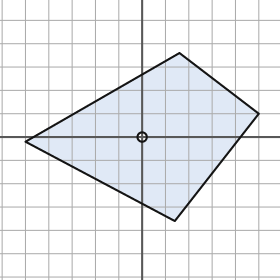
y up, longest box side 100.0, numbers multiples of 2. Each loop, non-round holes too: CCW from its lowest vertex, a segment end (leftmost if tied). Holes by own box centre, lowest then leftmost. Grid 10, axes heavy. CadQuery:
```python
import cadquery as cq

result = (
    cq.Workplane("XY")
    .moveTo(14.0, -36.0)
    .lineTo(50.0, 10.0)
    .lineTo(16.0, 36.0)
    .lineTo(-50.0, -2.0)
    .close()
    .moveTo(0.0, 0.0)
    .circle(2.0)
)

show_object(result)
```